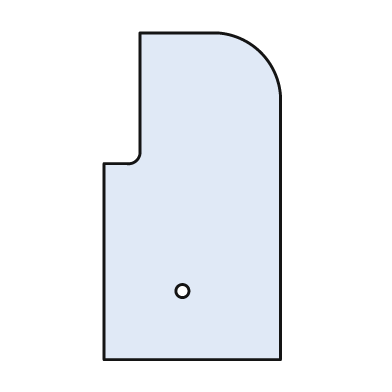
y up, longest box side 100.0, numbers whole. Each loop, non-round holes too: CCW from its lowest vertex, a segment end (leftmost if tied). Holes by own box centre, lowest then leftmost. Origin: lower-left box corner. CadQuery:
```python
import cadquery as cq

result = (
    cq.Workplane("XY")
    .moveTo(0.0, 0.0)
    .lineTo(54.0, 0.0)
    .lineTo(54.0, 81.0)
    .threePointArc((48.0, 94.0), (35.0, 100.0))
    .lineTo(11.0, 100.0)
    .lineTo(11.0, 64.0)
    .threePointArc((10.0, 61.0), (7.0, 60.0))
    .lineTo(0.0, 60.0)
    .close()
    .moveTo(24.0, 21.0)
    .circle(2.0)
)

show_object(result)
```